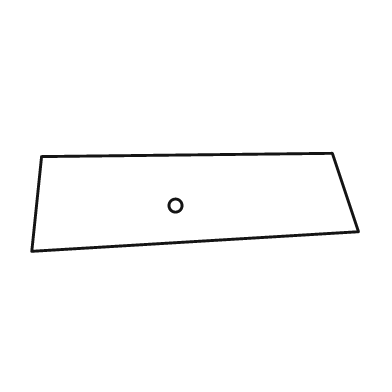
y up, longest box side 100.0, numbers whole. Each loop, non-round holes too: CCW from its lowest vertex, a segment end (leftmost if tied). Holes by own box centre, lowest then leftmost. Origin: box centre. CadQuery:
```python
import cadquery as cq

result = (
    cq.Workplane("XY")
    .moveTo(-50.0, -15.0)
    .lineTo(50.0, -9.0)
    .lineTo(42.0, 15.0)
    .lineTo(-47.0, 14.0)
    .close()
    .moveTo(-6.0, -1.0)
    .circle(2.0)
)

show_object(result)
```